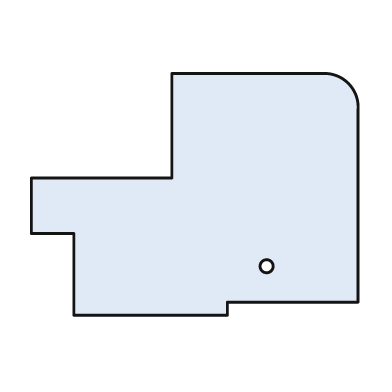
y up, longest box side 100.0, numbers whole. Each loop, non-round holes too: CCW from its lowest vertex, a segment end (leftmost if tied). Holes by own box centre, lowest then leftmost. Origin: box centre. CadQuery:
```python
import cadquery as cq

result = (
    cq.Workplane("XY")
    .moveTo(-37.0, -37.0)
    .lineTo(10.0, -37.0)
    .lineTo(10.0, -33.0)
    .lineTo(50.0, -33.0)
    .lineTo(50.0, 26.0)
    .threePointArc((47.0, 34.0), (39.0, 37.0))
    .lineTo(-7.0, 37.0)
    .lineTo(-7.0, 5.0)
    .lineTo(-50.0, 5.0)
    .lineTo(-50.0, -12.0)
    .lineTo(-37.0, -12.0)
    .close()
    .moveTo(22.0, -22.0)
    .circle(2.0)
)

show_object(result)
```